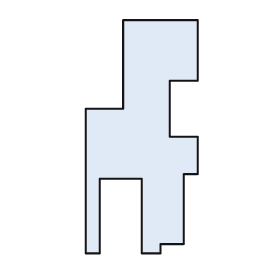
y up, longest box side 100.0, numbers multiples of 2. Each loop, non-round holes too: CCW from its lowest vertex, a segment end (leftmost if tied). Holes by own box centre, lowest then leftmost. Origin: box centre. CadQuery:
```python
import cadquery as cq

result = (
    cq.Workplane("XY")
    .moveTo(-24.0, -50.0)
    .lineTo(-18.0, -50.0)
    .lineTo(-18.0, -18.0)
    .lineTo(0.0, -18.0)
    .lineTo(0.0, -50.0)
    .lineTo(8.0, -50.0)
    .lineTo(8.0, -46.0)
    .lineTo(18.0, -46.0)
    .lineTo(18.0, -16.0)
    .lineTo(24.0, -16.0)
    .lineTo(24.0, 0.0)
    .lineTo(12.0, 0.0)
    .lineTo(12.0, 24.0)
    .lineTo(24.0, 24.0)
    .lineTo(24.0, 50.0)
    .lineTo(-8.0, 50.0)
    .lineTo(-8.0, 12.0)
    .lineTo(-24.0, 12.0)
    .close()
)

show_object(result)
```